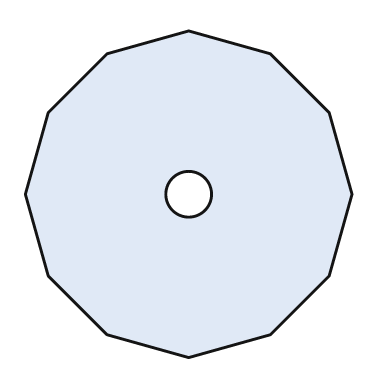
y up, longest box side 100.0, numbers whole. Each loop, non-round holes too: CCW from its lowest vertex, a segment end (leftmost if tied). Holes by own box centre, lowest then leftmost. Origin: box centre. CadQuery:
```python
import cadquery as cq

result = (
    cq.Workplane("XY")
    .moveTo(0.0, -50.0)
    .lineTo(25.0, -43.0)
    .lineTo(43.0, -25.0)
    .lineTo(50.0, 0.0)
    .lineTo(43.0, 25.0)
    .lineTo(25.0, 43.0)
    .lineTo(0.0, 50.0)
    .lineTo(-25.0, 43.0)
    .lineTo(-43.0, 25.0)
    .lineTo(-50.0, 0.0)
    .lineTo(-43.0, -25.0)
    .lineTo(-25.0, -43.0)
    .close()
    .moveTo(0.0, 0.0)
    .circle(7.0)
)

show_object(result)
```